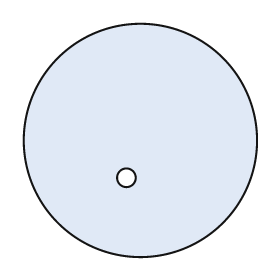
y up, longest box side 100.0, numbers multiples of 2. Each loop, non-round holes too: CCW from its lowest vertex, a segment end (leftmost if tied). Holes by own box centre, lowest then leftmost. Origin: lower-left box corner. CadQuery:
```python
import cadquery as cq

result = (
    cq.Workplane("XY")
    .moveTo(50.0, 50.0)
    .circle(50.0)
    .moveTo(44.0, 34.0)
    .circle(4.0)
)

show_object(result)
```